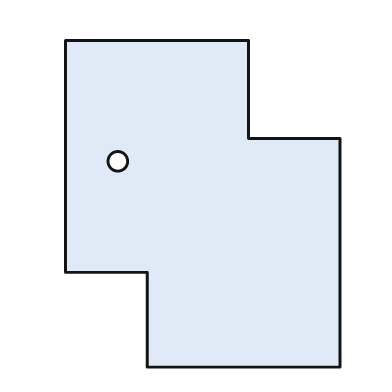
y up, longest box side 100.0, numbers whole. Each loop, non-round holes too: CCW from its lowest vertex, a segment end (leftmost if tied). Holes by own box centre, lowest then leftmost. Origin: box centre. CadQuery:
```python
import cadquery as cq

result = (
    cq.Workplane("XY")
    .moveTo(-17.0, -50.0)
    .lineTo(42.0, -50.0)
    .lineTo(42.0, 20.0)
    .lineTo(14.0, 20.0)
    .lineTo(14.0, 50.0)
    .lineTo(-42.0, 50.0)
    .lineTo(-42.0, -21.0)
    .lineTo(-17.0, -21.0)
    .close()
    .moveTo(-26.0, 13.0)
    .circle(3.0)
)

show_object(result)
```